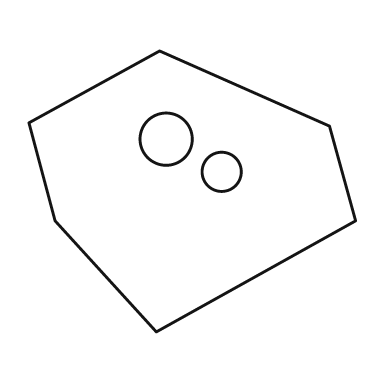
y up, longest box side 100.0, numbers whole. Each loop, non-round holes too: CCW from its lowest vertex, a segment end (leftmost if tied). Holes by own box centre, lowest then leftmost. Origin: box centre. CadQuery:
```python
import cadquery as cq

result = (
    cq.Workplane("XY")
    .moveTo(-11.0, -43.0)
    .lineTo(50.0, -9.0)
    .lineTo(42.0, 20.0)
    .lineTo(-10.0, 43.0)
    .lineTo(-50.0, 21.0)
    .lineTo(-42.0, -9.0)
    .close()
    .moveTo(9.0, 6.0)
    .circle(6.0)
    .moveTo(-8.0, 16.0)
    .circle(8.0)
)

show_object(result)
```